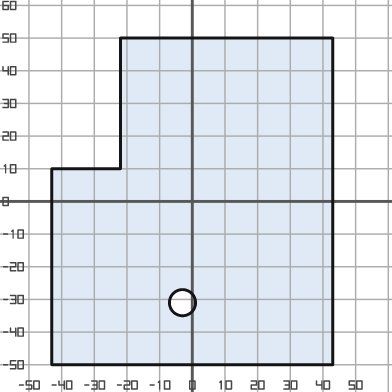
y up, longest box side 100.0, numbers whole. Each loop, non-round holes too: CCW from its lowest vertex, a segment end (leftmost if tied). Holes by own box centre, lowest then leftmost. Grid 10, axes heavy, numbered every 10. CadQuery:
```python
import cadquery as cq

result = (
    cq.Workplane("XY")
    .moveTo(-43.0, -50.0)
    .lineTo(43.0, -50.0)
    .lineTo(43.0, 50.0)
    .lineTo(-22.0, 50.0)
    .lineTo(-22.0, 10.0)
    .lineTo(-43.0, 10.0)
    .close()
    .moveTo(-3.0, -31.0)
    .circle(4.0)
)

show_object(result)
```